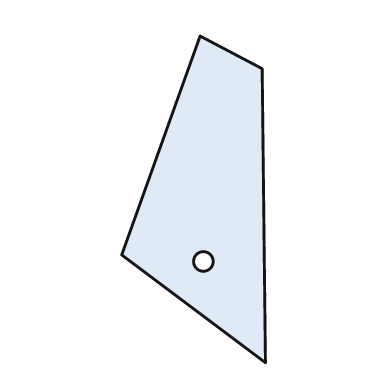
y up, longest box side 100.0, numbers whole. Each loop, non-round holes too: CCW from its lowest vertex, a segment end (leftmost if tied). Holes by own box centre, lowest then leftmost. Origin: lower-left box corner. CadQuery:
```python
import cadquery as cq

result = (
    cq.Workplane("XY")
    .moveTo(44.0, 0.0)
    .lineTo(43.0, 90.0)
    .lineTo(24.0, 100.0)
    .lineTo(0.0, 33.0)
    .close()
    .moveTo(25.0, 31.0)
    .circle(3.0)
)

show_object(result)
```